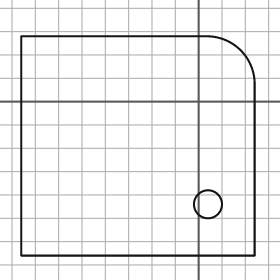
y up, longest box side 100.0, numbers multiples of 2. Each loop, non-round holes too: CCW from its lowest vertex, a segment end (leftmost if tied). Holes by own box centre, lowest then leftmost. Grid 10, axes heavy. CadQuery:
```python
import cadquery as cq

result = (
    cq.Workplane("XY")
    .moveTo(-76.0, -66.0)
    .lineTo(24.0, -66.0)
    .lineTo(24.0, 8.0)
    .threePointArc((18.0, 22.0), (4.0, 28.0))
    .lineTo(-76.0, 28.0)
    .close()
    .moveTo(4.0, -44.0)
    .circle(6.0)
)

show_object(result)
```